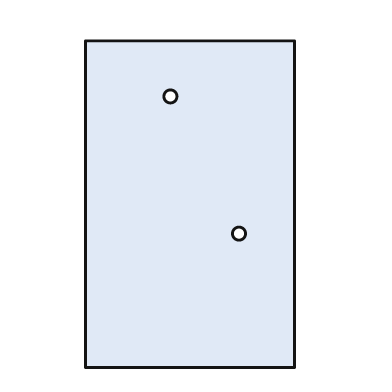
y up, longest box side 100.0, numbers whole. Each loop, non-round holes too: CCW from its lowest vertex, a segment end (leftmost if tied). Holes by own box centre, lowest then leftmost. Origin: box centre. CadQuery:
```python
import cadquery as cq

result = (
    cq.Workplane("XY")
    .moveTo(-32.0, -50.0)
    .lineTo(32.0, -50.0)
    .lineTo(32.0, 50.0)
    .lineTo(-32.0, 50.0)
    .close()
    .moveTo(15.0, -9.0)
    .circle(2.0)
    .moveTo(-6.0, 33.0)
    .circle(2.0)
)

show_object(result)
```